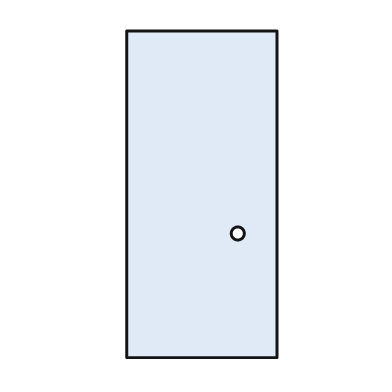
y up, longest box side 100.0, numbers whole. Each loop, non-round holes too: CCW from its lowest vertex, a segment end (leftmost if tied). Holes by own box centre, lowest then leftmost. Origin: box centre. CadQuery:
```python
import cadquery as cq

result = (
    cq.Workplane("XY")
    .moveTo(-23.0, -50.0)
    .lineTo(23.0, -50.0)
    .lineTo(23.0, 50.0)
    .lineTo(-23.0, 50.0)
    .close()
    .moveTo(11.0, -12.0)
    .circle(2.0)
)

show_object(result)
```